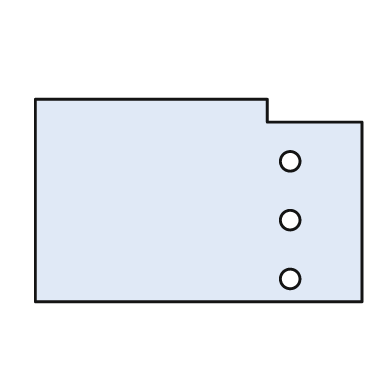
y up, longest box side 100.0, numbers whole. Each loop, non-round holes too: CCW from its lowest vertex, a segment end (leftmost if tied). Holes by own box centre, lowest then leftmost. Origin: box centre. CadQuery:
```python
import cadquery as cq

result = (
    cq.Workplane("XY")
    .moveTo(-50.0, -31.0)
    .lineTo(50.0, -31.0)
    .lineTo(50.0, 24.0)
    .lineTo(21.0, 24.0)
    .lineTo(21.0, 31.0)
    .lineTo(-50.0, 31.0)
    .close()
    .moveTo(28.0, -24.0)
    .circle(3.0)
    .moveTo(28.0, -6.0)
    .circle(3.0)
    .moveTo(28.0, 12.0)
    .circle(3.0)
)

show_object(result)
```